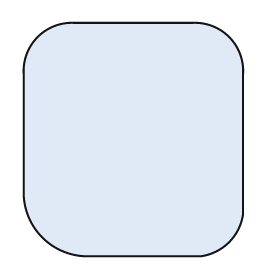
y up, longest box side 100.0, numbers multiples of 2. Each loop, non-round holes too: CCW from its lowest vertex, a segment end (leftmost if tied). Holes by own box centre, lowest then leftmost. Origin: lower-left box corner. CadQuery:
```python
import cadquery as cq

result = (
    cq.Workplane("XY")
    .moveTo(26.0, 0.0)
    .lineTo(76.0, 0.0)
    .threePointArc((88.0, 6.0), (94.0, 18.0))
    .lineTo(94.0, 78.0)
    .threePointArc((88.0, 94.0), (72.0, 100.0))
    .lineTo(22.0, 100.0)
    .threePointArc((6.0, 94.0), (0.0, 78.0))
    .lineTo(0.0, 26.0)
    .threePointArc((8.0, 8.0), (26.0, 0.0))
    .close()
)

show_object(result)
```